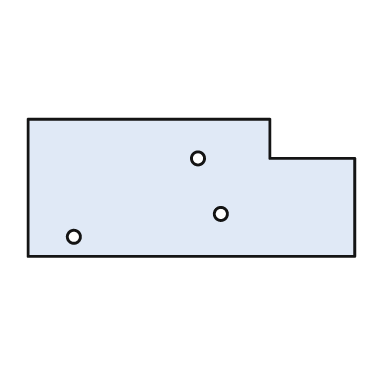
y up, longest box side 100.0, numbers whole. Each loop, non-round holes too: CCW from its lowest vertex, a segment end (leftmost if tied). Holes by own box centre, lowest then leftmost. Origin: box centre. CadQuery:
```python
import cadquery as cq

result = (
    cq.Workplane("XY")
    .moveTo(-50.0, -21.0)
    .lineTo(50.0, -21.0)
    .lineTo(50.0, 9.0)
    .lineTo(24.0, 9.0)
    .lineTo(24.0, 21.0)
    .lineTo(-50.0, 21.0)
    .close()
    .moveTo(-36.0, -15.0)
    .circle(2.0)
    .moveTo(9.0, -8.0)
    .circle(2.0)
    .moveTo(2.0, 9.0)
    .circle(2.0)
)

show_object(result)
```